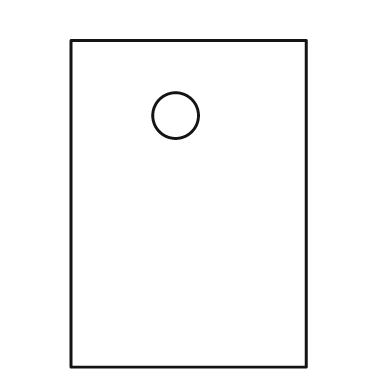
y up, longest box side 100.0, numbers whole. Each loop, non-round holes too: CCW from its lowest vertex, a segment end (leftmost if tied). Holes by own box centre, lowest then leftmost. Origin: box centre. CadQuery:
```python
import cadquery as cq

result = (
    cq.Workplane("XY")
    .moveTo(-36.0, -50.0)
    .lineTo(36.0, -50.0)
    .lineTo(36.0, 50.0)
    .lineTo(-36.0, 50.0)
    .close()
    .moveTo(-4.0, 27.0)
    .circle(7.0)
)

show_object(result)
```